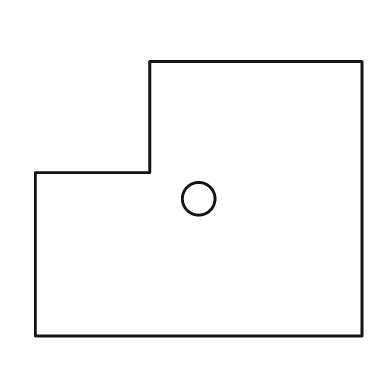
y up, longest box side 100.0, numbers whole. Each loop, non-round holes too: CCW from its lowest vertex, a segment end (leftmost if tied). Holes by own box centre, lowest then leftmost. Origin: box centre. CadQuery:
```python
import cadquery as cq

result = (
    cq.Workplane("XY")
    .moveTo(-50.0, -42.0)
    .lineTo(50.0, -42.0)
    .lineTo(50.0, 42.0)
    .lineTo(-15.0, 42.0)
    .lineTo(-15.0, 8.0)
    .lineTo(-50.0, 8.0)
    .close()
    .moveTo(0.0, 0.0)
    .circle(5.0)
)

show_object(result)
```